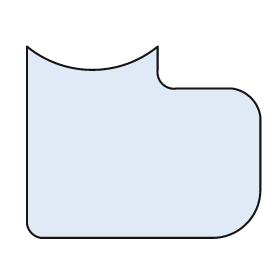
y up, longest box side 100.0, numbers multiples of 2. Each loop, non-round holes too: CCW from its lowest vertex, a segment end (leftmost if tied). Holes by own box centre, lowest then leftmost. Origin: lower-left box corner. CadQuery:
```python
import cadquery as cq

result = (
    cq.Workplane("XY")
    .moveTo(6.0, 0.0)
    .lineTo(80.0, 0.0)
    .threePointArc((94.0, 6.0), (100.0, 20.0))
    .lineTo(100.0, 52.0)
    .threePointArc((96.0, 60.0), (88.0, 64.0))
    .lineTo(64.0, 64.0)
    .threePointArc((58.0, 66.0), (56.0, 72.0))
    .lineTo(56.0, 82.0)
    .threePointArc((28.0, 72.0), (0.0, 82.0))
    .lineTo(0.0, 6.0)
    .threePointArc((2.0, 2.0), (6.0, 0.0))
    .close()
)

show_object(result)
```